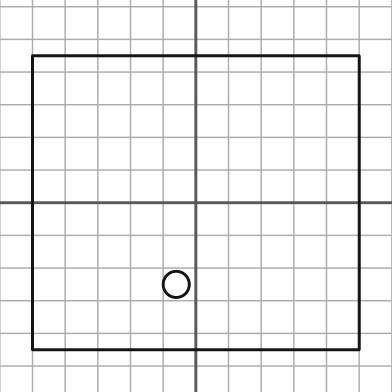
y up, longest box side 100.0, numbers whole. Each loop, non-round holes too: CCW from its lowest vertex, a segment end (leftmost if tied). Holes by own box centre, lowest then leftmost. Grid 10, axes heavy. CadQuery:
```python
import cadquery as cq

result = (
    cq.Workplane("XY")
    .moveTo(-50.0, -45.0)
    .lineTo(50.0, -45.0)
    .lineTo(50.0, 45.0)
    .lineTo(-50.0, 45.0)
    .close()
    .moveTo(-6.0, -25.0)
    .circle(4.0)
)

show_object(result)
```